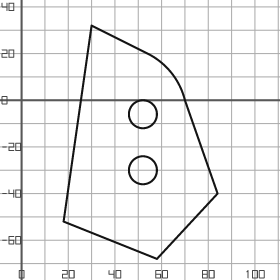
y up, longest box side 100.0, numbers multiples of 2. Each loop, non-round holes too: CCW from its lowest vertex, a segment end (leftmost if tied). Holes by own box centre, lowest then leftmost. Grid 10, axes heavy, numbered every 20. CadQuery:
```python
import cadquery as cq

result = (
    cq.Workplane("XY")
    .moveTo(58.0, -68.0)
    .lineTo(84.0, -40.0)
    .lineTo(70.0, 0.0)
    .threePointArc((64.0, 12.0), (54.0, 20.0))
    .lineTo(30.0, 32.0)
    .lineTo(18.0, -52.0)
    .close()
    .moveTo(52.0, -30.0)
    .circle(6.0)
    .moveTo(52.0, -6.0)
    .circle(6.0)
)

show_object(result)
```